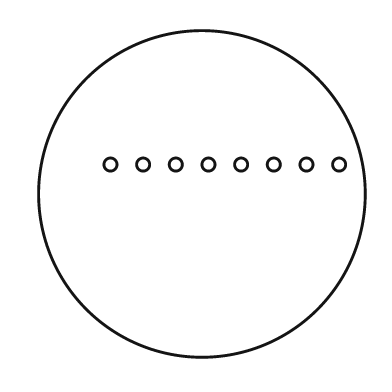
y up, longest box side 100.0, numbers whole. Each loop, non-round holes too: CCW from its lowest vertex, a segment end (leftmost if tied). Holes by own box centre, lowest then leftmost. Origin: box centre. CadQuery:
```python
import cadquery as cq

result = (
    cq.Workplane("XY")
    .moveTo(0.0, 0.0)
    .circle(50.0)
    .moveTo(-28.0, 9.0)
    .circle(2.0)
    .moveTo(-18.0, 9.0)
    .circle(2.0)
    .moveTo(-8.0, 9.0)
    .circle(2.0)
    .moveTo(2.0, 9.0)
    .circle(2.0)
    .moveTo(12.0, 9.0)
    .circle(2.0)
    .moveTo(22.0, 9.0)
    .circle(2.0)
    .moveTo(32.0, 9.0)
    .circle(2.0)
    .moveTo(42.0, 9.0)
    .circle(2.0)
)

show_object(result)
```